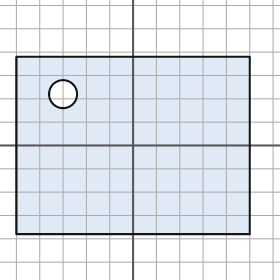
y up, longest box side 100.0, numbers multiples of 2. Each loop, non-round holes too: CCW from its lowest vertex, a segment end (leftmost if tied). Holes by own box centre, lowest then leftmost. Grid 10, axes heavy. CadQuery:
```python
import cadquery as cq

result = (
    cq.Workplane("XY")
    .moveTo(-50.0, -38.0)
    .lineTo(50.0, -38.0)
    .lineTo(50.0, 38.0)
    .lineTo(-50.0, 38.0)
    .close()
    .moveTo(-30.0, 22.0)
    .circle(6.0)
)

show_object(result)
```